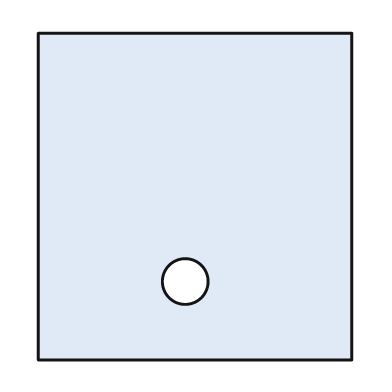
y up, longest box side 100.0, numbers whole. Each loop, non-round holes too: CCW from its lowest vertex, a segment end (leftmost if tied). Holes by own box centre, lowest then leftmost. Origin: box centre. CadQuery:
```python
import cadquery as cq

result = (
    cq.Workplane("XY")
    .moveTo(-48.0, -50.0)
    .lineTo(48.0, -50.0)
    .lineTo(48.0, 50.0)
    .lineTo(-48.0, 50.0)
    .close()
    .moveTo(-3.0, -26.0)
    .circle(7.0)
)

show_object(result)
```